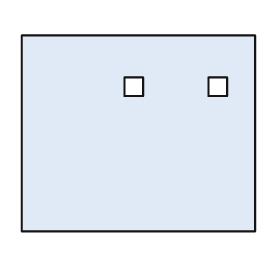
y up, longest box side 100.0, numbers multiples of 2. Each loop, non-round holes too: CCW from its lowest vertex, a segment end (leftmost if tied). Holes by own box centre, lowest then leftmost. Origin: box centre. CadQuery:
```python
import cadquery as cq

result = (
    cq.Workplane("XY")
    .moveTo(-50.0, -42.0)
    .lineTo(50.0, -42.0)
    .lineTo(50.0, 42.0)
    .lineTo(-50.0, 42.0)
    .close()
    .moveTo(-6.0, 16.0)
    .lineTo(2.0, 16.0)
    .lineTo(2.0, 24.0)
    .lineTo(-6.0, 24.0)
    .close()
    .moveTo(30.0, 16.0)
    .lineTo(38.0, 16.0)
    .lineTo(38.0, 24.0)
    .lineTo(30.0, 24.0)
    .close()
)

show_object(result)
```